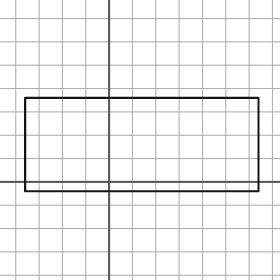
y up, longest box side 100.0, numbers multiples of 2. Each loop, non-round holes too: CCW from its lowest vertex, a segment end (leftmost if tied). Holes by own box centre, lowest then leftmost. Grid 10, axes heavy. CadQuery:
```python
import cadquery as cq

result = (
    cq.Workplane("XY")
    .moveTo(-36.0, -4.0)
    .lineTo(64.0, -4.0)
    .lineTo(64.0, 36.0)
    .lineTo(-36.0, 36.0)
    .close()
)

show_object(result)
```